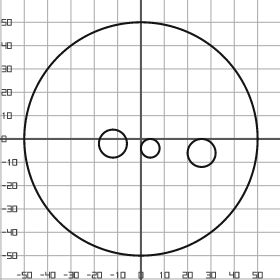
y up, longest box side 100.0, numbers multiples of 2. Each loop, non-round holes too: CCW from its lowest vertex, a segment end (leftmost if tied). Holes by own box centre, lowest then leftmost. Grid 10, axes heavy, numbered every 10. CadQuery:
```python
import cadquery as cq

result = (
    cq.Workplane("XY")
    .moveTo(0.0, 0.0)
    .circle(50.0)
    .moveTo(26.0, -6.0)
    .circle(6.0)
    .moveTo(4.0, -4.0)
    .circle(4.0)
    .moveTo(-12.0, -2.0)
    .circle(6.0)
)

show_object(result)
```